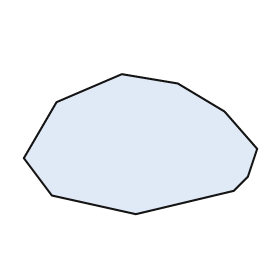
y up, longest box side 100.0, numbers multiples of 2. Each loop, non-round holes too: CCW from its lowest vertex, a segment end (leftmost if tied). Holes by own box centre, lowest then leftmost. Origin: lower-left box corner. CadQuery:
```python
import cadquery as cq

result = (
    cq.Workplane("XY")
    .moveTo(48.0, 0.0)
    .lineTo(90.0, 10.0)
    .lineTo(96.0, 16.0)
    .lineTo(100.0, 28.0)
    .lineTo(86.0, 44.0)
    .lineTo(66.0, 56.0)
    .lineTo(42.0, 60.0)
    .lineTo(14.0, 48.0)
    .lineTo(0.0, 24.0)
    .lineTo(12.0, 8.0)
    .close()
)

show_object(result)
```